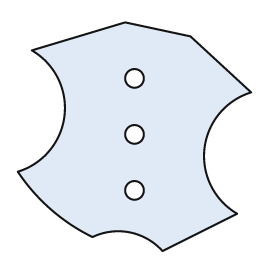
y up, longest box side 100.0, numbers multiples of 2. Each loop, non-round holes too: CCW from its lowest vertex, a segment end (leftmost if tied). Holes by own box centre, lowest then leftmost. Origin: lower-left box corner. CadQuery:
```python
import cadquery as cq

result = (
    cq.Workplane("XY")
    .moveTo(62.0, 0.0)
    .lineTo(94.0, 16.0)
    .threePointArc((80.0, 44.0), (100.0, 68.0))
    .lineTo(74.0, 92.0)
    .lineTo(46.0, 98.0)
    .lineTo(6.0, 86.0)
    .threePointArc((20.0, 58.0), (0.0, 34.0))
    .threePointArc((14.0, 18.0), (32.0, 6.0))
    .threePointArc((48.0, 8.0), (62.0, 0.0))
    .close()
    .moveTo(50.0, 26.0)
    .circle(4.0)
    .moveTo(50.0, 50.0)
    .circle(4.0)
    .moveTo(50.0, 74.0)
    .circle(4.0)
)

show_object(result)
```